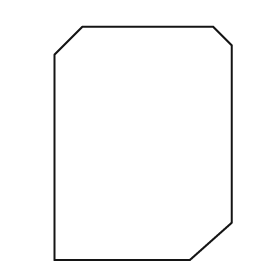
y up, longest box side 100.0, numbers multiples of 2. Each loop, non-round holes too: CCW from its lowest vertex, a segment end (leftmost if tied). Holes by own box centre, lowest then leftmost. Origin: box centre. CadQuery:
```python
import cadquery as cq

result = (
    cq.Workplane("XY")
    .moveTo(-38.0, -50.0)
    .lineTo(20.0, -50.0)
    .lineTo(38.0, -34.0)
    .lineTo(38.0, 42.0)
    .lineTo(30.0, 50.0)
    .lineTo(-26.0, 50.0)
    .lineTo(-38.0, 38.0)
    .close()
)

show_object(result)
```